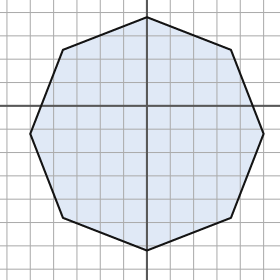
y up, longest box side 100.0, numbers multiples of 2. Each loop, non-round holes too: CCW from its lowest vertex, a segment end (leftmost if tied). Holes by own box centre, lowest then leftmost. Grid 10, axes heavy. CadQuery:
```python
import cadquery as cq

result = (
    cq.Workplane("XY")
    .moveTo(0.0, -62.0)
    .lineTo(36.0, -48.0)
    .lineTo(50.0, -12.0)
    .lineTo(36.0, 24.0)
    .lineTo(0.0, 38.0)
    .lineTo(-36.0, 24.0)
    .lineTo(-50.0, -12.0)
    .lineTo(-36.0, -48.0)
    .close()
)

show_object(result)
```